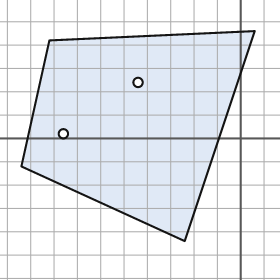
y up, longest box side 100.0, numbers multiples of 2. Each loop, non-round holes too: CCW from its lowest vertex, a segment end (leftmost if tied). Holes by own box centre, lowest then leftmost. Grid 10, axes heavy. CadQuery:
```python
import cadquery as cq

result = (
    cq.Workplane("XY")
    .moveTo(-24.0, -44.0)
    .lineTo(6.0, 46.0)
    .lineTo(-82.0, 42.0)
    .lineTo(-94.0, -12.0)
    .close()
    .moveTo(-76.0, 2.0)
    .circle(2.0)
    .moveTo(-44.0, 24.0)
    .circle(2.0)
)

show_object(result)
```